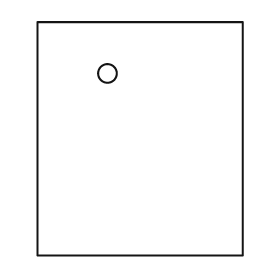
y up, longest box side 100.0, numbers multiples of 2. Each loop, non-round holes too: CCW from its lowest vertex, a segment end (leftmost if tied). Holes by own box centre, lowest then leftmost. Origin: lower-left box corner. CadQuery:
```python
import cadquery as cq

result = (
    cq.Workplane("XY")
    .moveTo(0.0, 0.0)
    .lineTo(88.0, 0.0)
    .lineTo(88.0, 100.0)
    .lineTo(0.0, 100.0)
    .close()
    .moveTo(30.0, 78.0)
    .circle(4.0)
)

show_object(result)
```